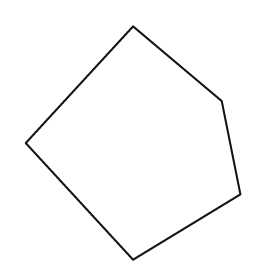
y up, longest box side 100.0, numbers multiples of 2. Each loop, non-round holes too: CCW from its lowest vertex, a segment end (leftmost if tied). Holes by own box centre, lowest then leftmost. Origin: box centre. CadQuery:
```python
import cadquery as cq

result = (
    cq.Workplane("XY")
    .moveTo(0.0, -50.0)
    .lineTo(46.0, -22.0)
    .lineTo(38.0, 18.0)
    .lineTo(0.0, 50.0)
    .lineTo(-46.0, 0.0)
    .close()
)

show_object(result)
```